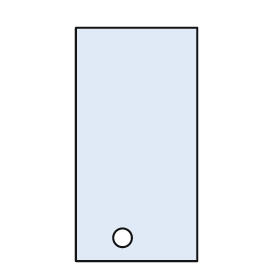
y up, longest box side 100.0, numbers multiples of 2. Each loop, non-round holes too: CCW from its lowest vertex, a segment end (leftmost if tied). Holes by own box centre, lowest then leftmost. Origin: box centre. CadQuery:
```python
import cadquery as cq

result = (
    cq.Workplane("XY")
    .moveTo(-26.0, -50.0)
    .lineTo(26.0, -50.0)
    .lineTo(26.0, 50.0)
    .lineTo(-26.0, 50.0)
    .close()
    .moveTo(-6.0, -40.0)
    .circle(4.0)
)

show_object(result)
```